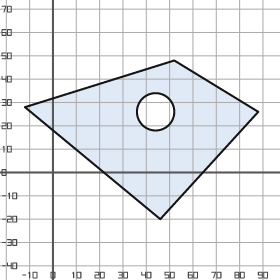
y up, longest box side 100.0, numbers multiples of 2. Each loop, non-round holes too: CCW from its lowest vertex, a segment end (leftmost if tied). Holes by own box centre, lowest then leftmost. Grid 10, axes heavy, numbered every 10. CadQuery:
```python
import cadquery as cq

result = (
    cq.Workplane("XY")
    .moveTo(46.0, -20.0)
    .lineTo(88.0, 26.0)
    .lineTo(52.0, 48.0)
    .lineTo(-12.0, 28.0)
    .close()
    .moveTo(44.0, 26.0)
    .circle(8.0)
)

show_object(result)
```